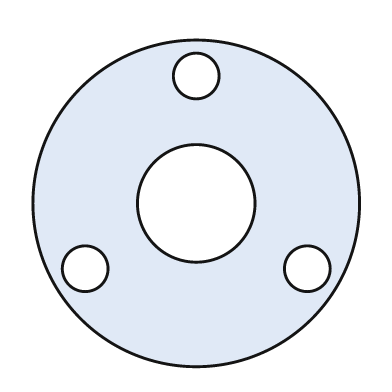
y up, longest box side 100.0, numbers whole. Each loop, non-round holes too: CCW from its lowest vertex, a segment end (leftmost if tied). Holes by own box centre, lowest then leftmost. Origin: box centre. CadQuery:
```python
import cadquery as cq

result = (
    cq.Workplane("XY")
    .moveTo(0.0, 0.0)
    .circle(50.0)
    .moveTo(-34.0, -20.0)
    .circle(7.0)
    .moveTo(34.0, -20.0)
    .circle(7.0)
    .moveTo(0.0, 0.0)
    .circle(18.0)
    .moveTo(0.0, 39.0)
    .circle(7.0)
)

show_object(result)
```